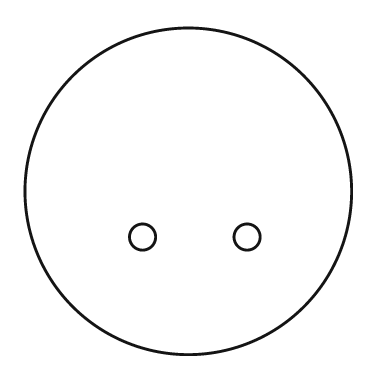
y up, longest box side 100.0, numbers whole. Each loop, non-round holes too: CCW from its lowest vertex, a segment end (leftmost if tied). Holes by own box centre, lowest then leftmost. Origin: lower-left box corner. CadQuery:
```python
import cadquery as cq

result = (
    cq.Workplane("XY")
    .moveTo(50.0, 50.0)
    .circle(50.0)
    .moveTo(36.0, 36.0)
    .circle(4.0)
    .moveTo(68.0, 36.0)
    .circle(4.0)
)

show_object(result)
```